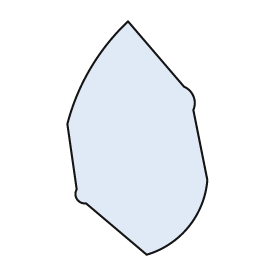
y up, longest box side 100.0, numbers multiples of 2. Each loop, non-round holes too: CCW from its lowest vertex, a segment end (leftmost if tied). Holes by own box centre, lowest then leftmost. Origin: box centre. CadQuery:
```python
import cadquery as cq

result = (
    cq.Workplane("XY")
    .moveTo(4.0, -50.0)
    .threePointArc((22.0, -38.0), (30.0, -18.0))
    .lineTo(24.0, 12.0)
    .threePointArc((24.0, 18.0), (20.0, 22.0))
    .lineTo(-4.0, 50.0)
    .threePointArc((-20.0, 30.0), (-30.0, 6.0))
    .lineTo(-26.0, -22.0)
    .threePointArc((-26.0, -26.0), (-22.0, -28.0))
    .close()
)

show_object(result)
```